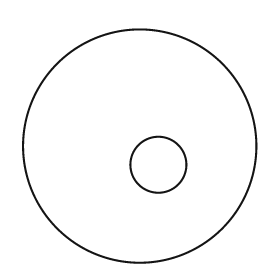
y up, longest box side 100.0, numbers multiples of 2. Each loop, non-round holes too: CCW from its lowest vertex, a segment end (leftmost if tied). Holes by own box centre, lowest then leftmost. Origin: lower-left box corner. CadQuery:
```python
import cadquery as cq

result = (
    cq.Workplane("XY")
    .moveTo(50.0, 50.0)
    .circle(50.0)
    .moveTo(58.0, 42.0)
    .circle(12.0)
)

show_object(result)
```